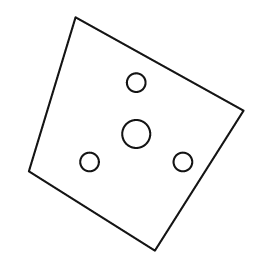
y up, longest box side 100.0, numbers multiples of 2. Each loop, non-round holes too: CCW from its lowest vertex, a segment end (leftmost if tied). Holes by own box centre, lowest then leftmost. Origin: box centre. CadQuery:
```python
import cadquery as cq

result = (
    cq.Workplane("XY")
    .moveTo(8.0, -50.0)
    .lineTo(46.0, 10.0)
    .lineTo(-26.0, 50.0)
    .lineTo(-46.0, -16.0)
    .close()
    .moveTo(-20.0, -12.0)
    .circle(4.0)
    .moveTo(20.0, -12.0)
    .circle(4.0)
    .moveTo(0.0, 0.0)
    .circle(6.0)
    .moveTo(0.0, 22.0)
    .circle(4.0)
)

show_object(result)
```